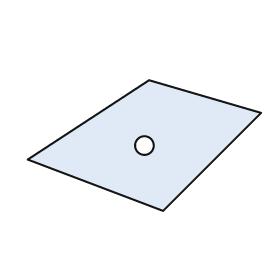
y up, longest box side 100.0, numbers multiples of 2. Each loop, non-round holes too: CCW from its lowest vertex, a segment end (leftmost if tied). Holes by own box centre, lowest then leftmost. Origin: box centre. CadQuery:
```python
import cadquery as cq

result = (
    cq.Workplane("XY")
    .moveTo(8.0, -28.0)
    .lineTo(50.0, 14.0)
    .lineTo(2.0, 28.0)
    .lineTo(-50.0, -6.0)
    .close()
    .moveTo(0.0, 0.0)
    .circle(4.0)
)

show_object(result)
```